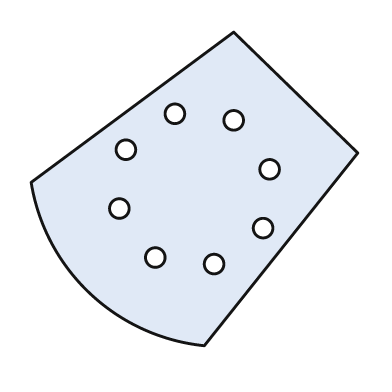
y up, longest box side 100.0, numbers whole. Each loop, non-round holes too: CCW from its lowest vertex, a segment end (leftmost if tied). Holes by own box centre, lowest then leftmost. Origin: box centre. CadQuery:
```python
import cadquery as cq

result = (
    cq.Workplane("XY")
    .moveTo(3.0, -48.0)
    .lineTo(50.0, 11.0)
    .lineTo(12.0, 48.0)
    .lineTo(-50.0, 2.0)
    .threePointArc((-32.0, -32.0), (3.0, -48.0))
    .close()
    .moveTo(6.0, -23.0)
    .circle(3.0)
    .moveTo(-12.0, -21.0)
    .circle(3.0)
    .moveTo(21.0, -12.0)
    .circle(3.0)
    .moveTo(-23.0, -6.0)
    .circle(3.0)
    .moveTo(23.0, 6.0)
    .circle(3.0)
    .moveTo(-21.0, 12.0)
    .circle(3.0)
    .moveTo(12.0, 21.0)
    .circle(3.0)
    .moveTo(-6.0, 23.0)
    .circle(3.0)
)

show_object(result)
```